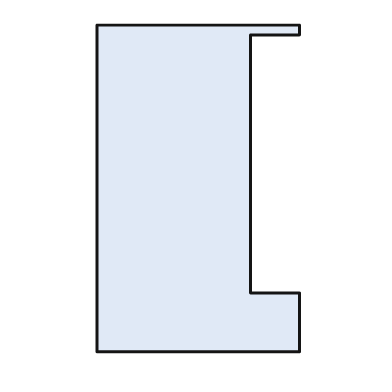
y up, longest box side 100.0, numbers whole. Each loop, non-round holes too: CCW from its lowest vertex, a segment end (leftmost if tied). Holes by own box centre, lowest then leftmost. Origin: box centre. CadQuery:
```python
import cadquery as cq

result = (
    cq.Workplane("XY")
    .moveTo(-31.0, -50.0)
    .lineTo(31.0, -50.0)
    .lineTo(31.0, -32.0)
    .lineTo(16.0, -32.0)
    .lineTo(16.0, 47.0)
    .lineTo(31.0, 47.0)
    .lineTo(31.0, 50.0)
    .lineTo(-31.0, 50.0)
    .close()
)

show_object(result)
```